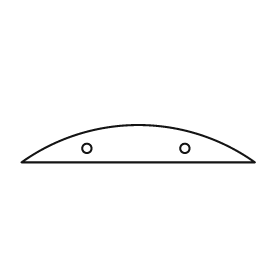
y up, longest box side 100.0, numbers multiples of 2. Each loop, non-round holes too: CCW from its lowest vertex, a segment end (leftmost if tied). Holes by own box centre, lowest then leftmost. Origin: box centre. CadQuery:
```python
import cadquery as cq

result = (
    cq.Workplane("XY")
    .moveTo(-50.0, -8.0)
    .lineTo(50.0, -8.0)
    .threePointArc((0.0, 8.0), (-50.0, -8.0))
    .close()
    .moveTo(-22.0, -2.0)
    .circle(2.0)
    .moveTo(20.0, -2.0)
    .circle(2.0)
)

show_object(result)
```